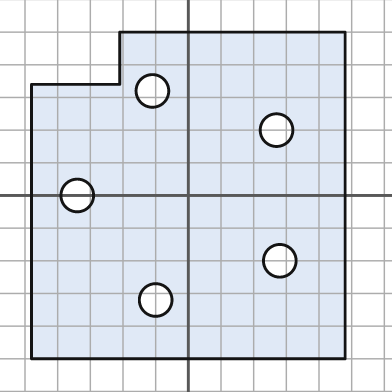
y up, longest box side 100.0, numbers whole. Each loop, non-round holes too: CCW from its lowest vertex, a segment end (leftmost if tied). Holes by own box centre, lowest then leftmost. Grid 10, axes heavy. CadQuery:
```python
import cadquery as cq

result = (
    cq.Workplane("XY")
    .moveTo(-48.0, -50.0)
    .lineTo(48.0, -50.0)
    .lineTo(48.0, 50.0)
    .lineTo(-21.0, 50.0)
    .lineTo(-21.0, 34.0)
    .lineTo(-48.0, 34.0)
    .close()
    .moveTo(-10.0, -32.0)
    .circle(5.0)
    .moveTo(28.0, -20.0)
    .circle(5.0)
    .moveTo(-34.0, 0.0)
    .circle(5.0)
    .moveTo(27.0, 20.0)
    .circle(5.0)
    .moveTo(-11.0, 32.0)
    .circle(5.0)
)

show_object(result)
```